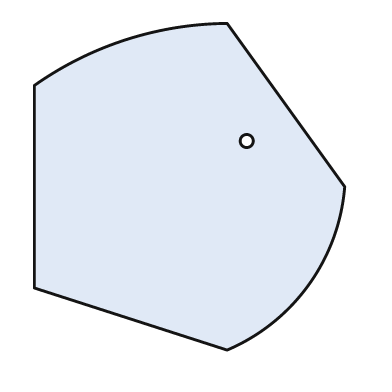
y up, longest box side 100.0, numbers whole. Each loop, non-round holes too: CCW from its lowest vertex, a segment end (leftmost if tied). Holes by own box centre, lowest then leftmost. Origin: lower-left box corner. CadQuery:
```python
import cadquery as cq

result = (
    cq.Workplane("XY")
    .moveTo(59.0, 0.0)
    .threePointArc((84.0, 20.0), (95.0, 50.0))
    .lineTo(59.0, 100.0)
    .threePointArc((28.0, 95.0), (0.0, 81.0))
    .lineTo(0.0, 19.0)
    .close()
    .moveTo(65.0, 64.0)
    .circle(2.0)
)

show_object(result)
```